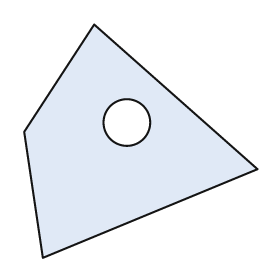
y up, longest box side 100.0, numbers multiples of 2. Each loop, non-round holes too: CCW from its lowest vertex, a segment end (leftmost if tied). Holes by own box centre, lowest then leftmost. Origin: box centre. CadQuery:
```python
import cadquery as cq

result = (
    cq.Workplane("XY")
    .moveTo(-42.0, -50.0)
    .lineTo(50.0, -12.0)
    .lineTo(-20.0, 50.0)
    .lineTo(-50.0, 4.0)
    .close()
    .moveTo(-6.0, 8.0)
    .circle(10.0)
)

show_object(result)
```